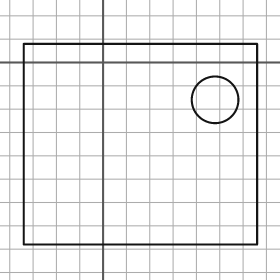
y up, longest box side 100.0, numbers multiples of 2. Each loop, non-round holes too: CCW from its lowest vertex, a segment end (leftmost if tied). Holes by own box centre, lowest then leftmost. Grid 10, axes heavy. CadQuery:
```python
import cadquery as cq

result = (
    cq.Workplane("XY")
    .moveTo(-34.0, -78.0)
    .lineTo(66.0, -78.0)
    .lineTo(66.0, 8.0)
    .lineTo(-34.0, 8.0)
    .close()
    .moveTo(48.0, -16.0)
    .circle(10.0)
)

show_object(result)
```